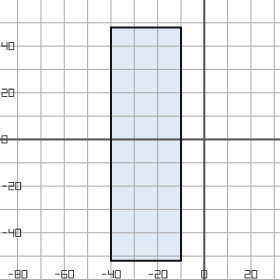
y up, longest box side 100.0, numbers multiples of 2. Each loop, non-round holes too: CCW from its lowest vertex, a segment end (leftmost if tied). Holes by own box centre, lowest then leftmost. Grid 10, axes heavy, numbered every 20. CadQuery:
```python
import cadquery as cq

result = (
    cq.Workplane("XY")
    .moveTo(-40.0, -52.0)
    .lineTo(-10.0, -52.0)
    .lineTo(-10.0, 48.0)
    .lineTo(-40.0, 48.0)
    .close()
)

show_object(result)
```